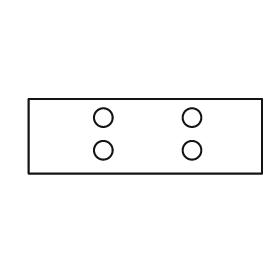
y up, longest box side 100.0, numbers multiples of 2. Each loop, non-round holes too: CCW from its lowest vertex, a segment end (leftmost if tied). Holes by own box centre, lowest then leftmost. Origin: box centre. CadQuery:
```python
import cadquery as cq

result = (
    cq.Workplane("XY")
    .moveTo(-50.0, -16.0)
    .lineTo(50.0, -16.0)
    .lineTo(50.0, 16.0)
    .lineTo(-50.0, 16.0)
    .close()
    .moveTo(-18.0, -6.0)
    .circle(4.0)
    .moveTo(20.0, -6.0)
    .circle(4.0)
    .moveTo(-18.0, 8.0)
    .circle(4.0)
    .moveTo(20.0, 8.0)
    .circle(4.0)
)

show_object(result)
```